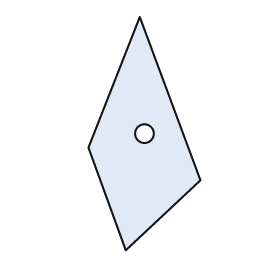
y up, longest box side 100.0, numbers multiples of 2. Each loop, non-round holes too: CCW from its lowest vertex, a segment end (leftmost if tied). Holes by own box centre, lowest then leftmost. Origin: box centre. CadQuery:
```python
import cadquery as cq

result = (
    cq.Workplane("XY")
    .moveTo(-8.0, -50.0)
    .lineTo(24.0, -20.0)
    .lineTo(-2.0, 50.0)
    .lineTo(-24.0, -6.0)
    .close()
    .moveTo(0.0, 0.0)
    .circle(4.0)
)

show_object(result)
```